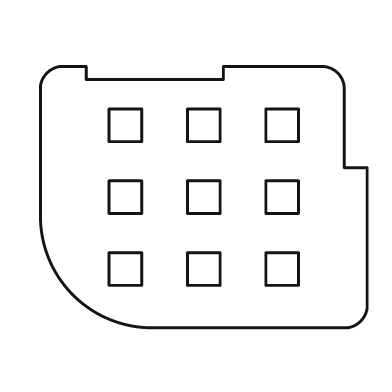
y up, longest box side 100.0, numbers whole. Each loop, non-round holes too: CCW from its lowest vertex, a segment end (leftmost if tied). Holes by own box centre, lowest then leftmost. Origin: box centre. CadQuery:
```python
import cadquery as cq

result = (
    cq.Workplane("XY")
    .moveTo(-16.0, -40.0)
    .lineTo(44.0, -40.0)
    .threePointArc((48.0, -38.0), (50.0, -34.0))
    .lineTo(50.0, 9.0)
    .lineTo(43.0, 9.0)
    .lineTo(43.0, 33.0)
    .threePointArc((41.0, 38.0), (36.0, 40.0))
    .lineTo(6.0, 40.0)
    .lineTo(6.0, 36.0)
    .lineTo(-36.0, 36.0)
    .lineTo(-36.0, 40.0)
    .lineTo(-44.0, 40.0)
    .threePointArc((-48.0, 38.0), (-50.0, 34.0))
    .lineTo(-50.0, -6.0)
    .threePointArc((-40.0, -30.0), (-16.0, -40.0))
    .close()
    .moveTo(-29.0, -27.0)
    .lineTo(-19.0, -27.0)
    .lineTo(-19.0, -17.0)
    .lineTo(-29.0, -17.0)
    .close()
    .moveTo(-5.0, -27.0)
    .lineTo(5.0, -27.0)
    .lineTo(5.0, -17.0)
    .lineTo(-5.0, -17.0)
    .close()
    .moveTo(19.0, -27.0)
    .lineTo(29.0, -27.0)
    .lineTo(29.0, -17.0)
    .lineTo(19.0, -17.0)
    .close()
    .moveTo(-29.0, -5.0)
    .lineTo(-19.0, -5.0)
    .lineTo(-19.0, 5.0)
    .lineTo(-29.0, 5.0)
    .close()
    .moveTo(-5.0, -5.0)
    .lineTo(5.0, -5.0)
    .lineTo(5.0, 5.0)
    .lineTo(-5.0, 5.0)
    .close()
    .moveTo(19.0, -5.0)
    .lineTo(29.0, -5.0)
    .lineTo(29.0, 5.0)
    .lineTo(19.0, 5.0)
    .close()
    .moveTo(-29.0, 17.0)
    .lineTo(-19.0, 17.0)
    .lineTo(-19.0, 27.0)
    .lineTo(-29.0, 27.0)
    .close()
    .moveTo(-5.0, 17.0)
    .lineTo(5.0, 17.0)
    .lineTo(5.0, 27.0)
    .lineTo(-5.0, 27.0)
    .close()
    .moveTo(19.0, 17.0)
    .lineTo(29.0, 17.0)
    .lineTo(29.0, 27.0)
    .lineTo(19.0, 27.0)
    .close()
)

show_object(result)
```